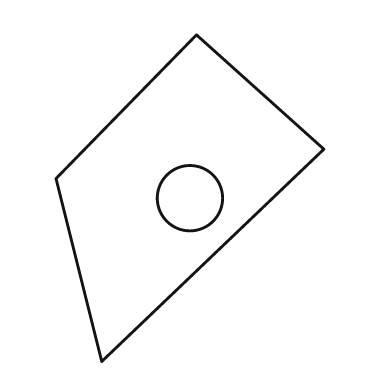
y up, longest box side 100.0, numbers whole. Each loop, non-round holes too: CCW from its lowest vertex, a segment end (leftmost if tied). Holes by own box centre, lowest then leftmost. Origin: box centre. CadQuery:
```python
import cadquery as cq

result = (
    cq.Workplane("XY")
    .moveTo(-27.0, -50.0)
    .lineTo(41.0, 15.0)
    .lineTo(2.0, 50.0)
    .lineTo(-41.0, 6.0)
    .close()
    .moveTo(0.0, 0.0)
    .circle(10.0)
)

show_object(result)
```